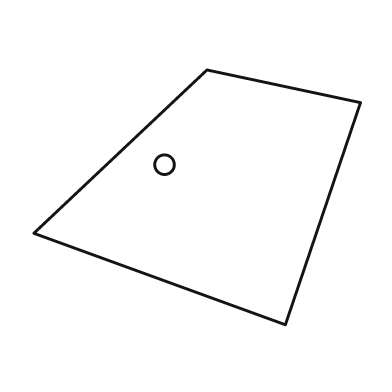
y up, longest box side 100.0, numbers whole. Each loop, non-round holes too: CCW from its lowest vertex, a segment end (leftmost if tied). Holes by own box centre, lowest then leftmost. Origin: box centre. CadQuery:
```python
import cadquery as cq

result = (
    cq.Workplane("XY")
    .moveTo(27.0, -39.0)
    .lineTo(50.0, 29.0)
    .lineTo(3.0, 39.0)
    .lineTo(-50.0, -11.0)
    .close()
    .moveTo(-10.0, 10.0)
    .circle(3.0)
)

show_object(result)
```